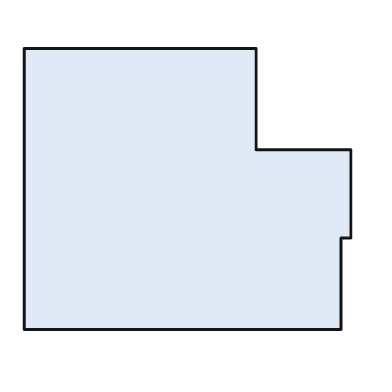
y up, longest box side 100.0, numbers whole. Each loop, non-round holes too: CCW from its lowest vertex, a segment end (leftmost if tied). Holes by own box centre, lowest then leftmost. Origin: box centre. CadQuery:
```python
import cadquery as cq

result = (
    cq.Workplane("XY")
    .moveTo(-50.0, -43.0)
    .lineTo(47.0, -43.0)
    .lineTo(47.0, -15.0)
    .lineTo(50.0, -15.0)
    .lineTo(50.0, 12.0)
    .lineTo(21.0, 12.0)
    .lineTo(21.0, 43.0)
    .lineTo(-50.0, 43.0)
    .close()
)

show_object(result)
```